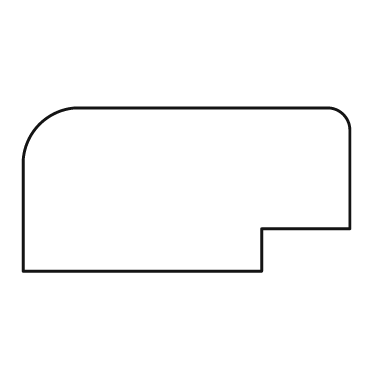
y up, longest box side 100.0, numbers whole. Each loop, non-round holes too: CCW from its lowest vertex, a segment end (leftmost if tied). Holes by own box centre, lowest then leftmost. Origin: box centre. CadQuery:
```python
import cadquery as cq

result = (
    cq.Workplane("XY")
    .moveTo(-50.0, -25.0)
    .lineTo(23.0, -25.0)
    .lineTo(23.0, -12.0)
    .lineTo(50.0, -12.0)
    .lineTo(50.0, 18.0)
    .threePointArc((48.0, 23.0), (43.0, 25.0))
    .lineTo(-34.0, 25.0)
    .threePointArc((-45.0, 20.0), (-50.0, 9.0))
    .close()
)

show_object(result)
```